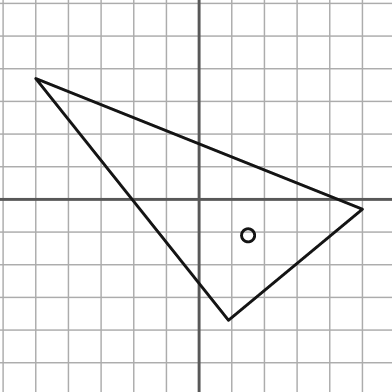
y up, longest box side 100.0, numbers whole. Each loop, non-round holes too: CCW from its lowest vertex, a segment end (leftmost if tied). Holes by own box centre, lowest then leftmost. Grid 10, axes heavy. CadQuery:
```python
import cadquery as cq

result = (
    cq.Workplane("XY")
    .moveTo(9.0, -37.0)
    .lineTo(50.0, -3.0)
    .lineTo(-50.0, 37.0)
    .close()
    .moveTo(15.0, -11.0)
    .circle(2.0)
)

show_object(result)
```